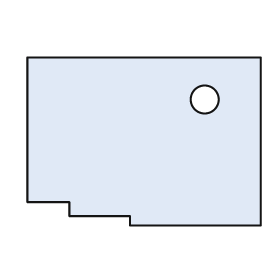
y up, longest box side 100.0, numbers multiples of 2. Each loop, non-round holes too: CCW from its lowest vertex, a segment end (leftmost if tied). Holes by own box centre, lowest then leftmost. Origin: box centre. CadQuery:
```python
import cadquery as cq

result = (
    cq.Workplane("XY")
    .moveTo(-6.0, -36.0)
    .lineTo(50.0, -36.0)
    .lineTo(50.0, 36.0)
    .lineTo(-50.0, 36.0)
    .lineTo(-50.0, -26.0)
    .lineTo(-32.0, -26.0)
    .lineTo(-32.0, -32.0)
    .lineTo(-6.0, -32.0)
    .close()
    .moveTo(26.0, 18.0)
    .circle(6.0)
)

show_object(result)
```